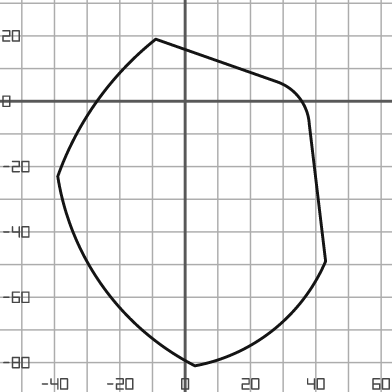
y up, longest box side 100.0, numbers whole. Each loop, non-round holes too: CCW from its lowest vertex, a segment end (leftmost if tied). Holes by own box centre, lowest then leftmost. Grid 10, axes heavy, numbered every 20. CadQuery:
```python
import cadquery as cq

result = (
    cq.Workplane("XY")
    .moveTo(3.0, -81.0)
    .threePointArc((27.0, -70.0), (43.0, -49.0))
    .lineTo(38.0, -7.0)
    .threePointArc((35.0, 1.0), (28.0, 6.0))
    .lineTo(-9.0, 19.0)
    .threePointArc((-27.0, 0.0), (-39.0, -23.0))
    .threePointArc((-25.0, -57.0), (3.0, -81.0))
    .close()
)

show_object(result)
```